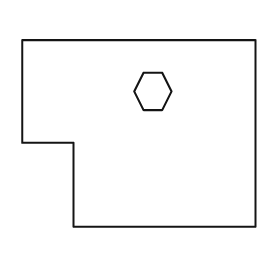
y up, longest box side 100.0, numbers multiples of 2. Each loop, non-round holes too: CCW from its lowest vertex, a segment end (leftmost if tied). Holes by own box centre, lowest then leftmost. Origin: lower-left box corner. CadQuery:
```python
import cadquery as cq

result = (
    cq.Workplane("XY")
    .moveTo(22.0, 0.0)
    .lineTo(100.0, 0.0)
    .lineTo(100.0, 80.0)
    .lineTo(0.0, 80.0)
    .lineTo(0.0, 36.0)
    .lineTo(22.0, 36.0)
    .close()
    .moveTo(52.0, 50.0)
    .lineTo(60.0, 50.0)
    .lineTo(64.0, 58.0)
    .lineTo(60.0, 66.0)
    .lineTo(52.0, 66.0)
    .lineTo(48.0, 58.0)
    .close()
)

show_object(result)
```